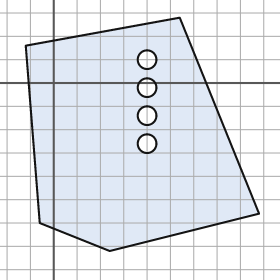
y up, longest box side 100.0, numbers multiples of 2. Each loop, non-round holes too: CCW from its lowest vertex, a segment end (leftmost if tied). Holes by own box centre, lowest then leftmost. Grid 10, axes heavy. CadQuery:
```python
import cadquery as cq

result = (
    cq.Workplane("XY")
    .moveTo(24.0, -72.0)
    .lineTo(88.0, -56.0)
    .lineTo(54.0, 28.0)
    .lineTo(-12.0, 16.0)
    .lineTo(-6.0, -60.0)
    .close()
    .moveTo(40.0, -26.0)
    .circle(4.0)
    .moveTo(40.0, -14.0)
    .circle(4.0)
    .moveTo(40.0, -2.0)
    .circle(4.0)
    .moveTo(40.0, 10.0)
    .circle(4.0)
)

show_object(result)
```